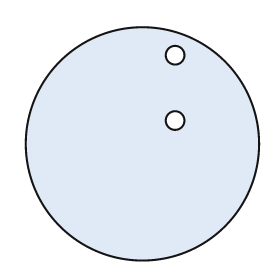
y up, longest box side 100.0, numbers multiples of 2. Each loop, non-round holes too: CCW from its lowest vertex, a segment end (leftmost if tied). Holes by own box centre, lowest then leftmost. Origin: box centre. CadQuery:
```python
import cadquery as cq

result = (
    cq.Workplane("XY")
    .moveTo(0.0, 0.0)
    .circle(50.0)
    .moveTo(14.0, 10.0)
    .circle(4.0)
    .moveTo(14.0, 38.0)
    .circle(4.0)
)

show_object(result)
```